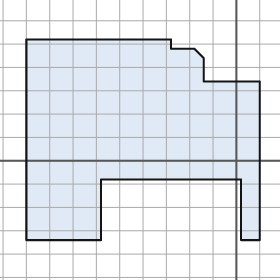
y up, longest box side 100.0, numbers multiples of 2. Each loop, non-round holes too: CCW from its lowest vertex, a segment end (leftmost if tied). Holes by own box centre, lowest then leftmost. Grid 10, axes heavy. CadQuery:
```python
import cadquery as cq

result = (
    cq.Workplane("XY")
    .moveTo(-90.0, -34.0)
    .lineTo(-58.0, -34.0)
    .lineTo(-58.0, -8.0)
    .lineTo(2.0, -8.0)
    .lineTo(2.0, -34.0)
    .lineTo(10.0, -34.0)
    .lineTo(10.0, 34.0)
    .lineTo(-14.0, 34.0)
    .lineTo(-14.0, 44.0)
    .lineTo(-18.0, 48.0)
    .lineTo(-28.0, 48.0)
    .lineTo(-28.0, 52.0)
    .lineTo(-90.0, 52.0)
    .close()
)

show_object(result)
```